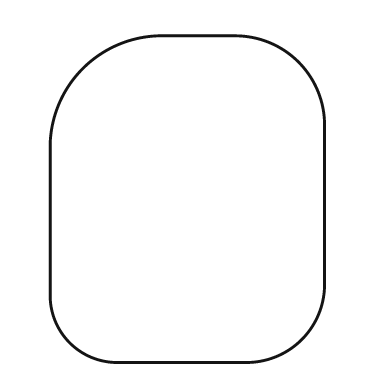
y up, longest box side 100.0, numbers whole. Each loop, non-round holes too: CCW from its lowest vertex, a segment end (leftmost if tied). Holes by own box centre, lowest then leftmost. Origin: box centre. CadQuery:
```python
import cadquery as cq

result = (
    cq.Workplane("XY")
    .moveTo(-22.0, -50.0)
    .lineTo(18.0, -50.0)
    .threePointArc((35.0, -43.0), (42.0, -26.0))
    .lineTo(42.0, 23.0)
    .threePointArc((34.0, 42.0), (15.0, 50.0))
    .lineTo(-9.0, 50.0)
    .threePointArc((-32.0, 40.0), (-42.0, 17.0))
    .lineTo(-42.0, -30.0)
    .threePointArc((-36.0, -44.0), (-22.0, -50.0))
    .close()
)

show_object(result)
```